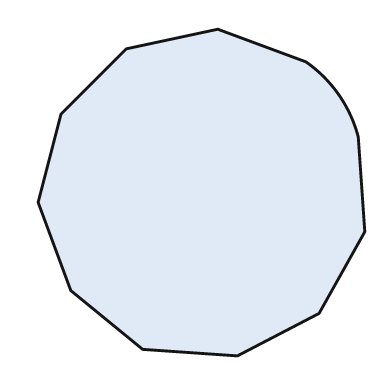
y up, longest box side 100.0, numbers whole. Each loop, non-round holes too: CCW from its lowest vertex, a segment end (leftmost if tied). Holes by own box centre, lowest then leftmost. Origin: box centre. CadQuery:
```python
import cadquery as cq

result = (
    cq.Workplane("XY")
    .moveTo(11.0, -50.0)
    .lineTo(36.0, -37.0)
    .lineTo(50.0, -12.0)
    .lineTo(48.0, 17.0)
    .threePointArc((42.0, 30.0), (32.0, 40.0))
    .lineTo(5.0, 50.0)
    .lineTo(-23.0, 44.0)
    .lineTo(-43.0, 24.0)
    .lineTo(-50.0, -3.0)
    .lineTo(-40.0, -30.0)
    .lineTo(-18.0, -48.0)
    .close()
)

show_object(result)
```